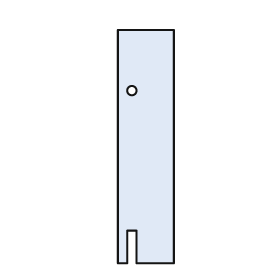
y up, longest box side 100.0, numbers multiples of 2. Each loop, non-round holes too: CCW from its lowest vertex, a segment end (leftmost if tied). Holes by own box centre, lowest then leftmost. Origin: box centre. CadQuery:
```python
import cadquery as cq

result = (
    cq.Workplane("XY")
    .moveTo(-12.0, -50.0)
    .lineTo(-8.0, -50.0)
    .lineTo(-8.0, -36.0)
    .lineTo(-4.0, -36.0)
    .lineTo(-4.0, -50.0)
    .lineTo(12.0, -50.0)
    .lineTo(12.0, 50.0)
    .lineTo(-12.0, 50.0)
    .close()
    .moveTo(-6.0, 24.0)
    .circle(2.0)
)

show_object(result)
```